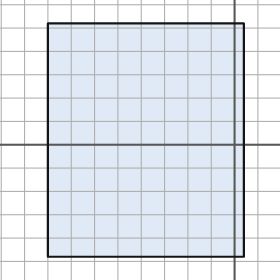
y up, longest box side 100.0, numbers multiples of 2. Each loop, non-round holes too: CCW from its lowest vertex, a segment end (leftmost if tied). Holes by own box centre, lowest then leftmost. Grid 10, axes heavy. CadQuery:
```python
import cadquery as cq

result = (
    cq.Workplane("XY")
    .moveTo(-80.0, -48.0)
    .lineTo(4.0, -48.0)
    .lineTo(4.0, 52.0)
    .lineTo(-80.0, 52.0)
    .close()
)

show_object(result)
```